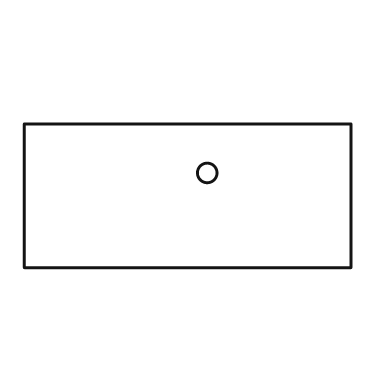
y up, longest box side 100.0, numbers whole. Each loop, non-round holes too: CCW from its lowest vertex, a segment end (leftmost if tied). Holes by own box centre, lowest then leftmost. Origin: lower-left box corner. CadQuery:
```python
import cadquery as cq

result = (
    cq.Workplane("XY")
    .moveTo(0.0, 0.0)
    .lineTo(100.0, 0.0)
    .lineTo(100.0, 44.0)
    .lineTo(0.0, 44.0)
    .close()
    .moveTo(56.0, 29.0)
    .circle(3.0)
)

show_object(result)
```